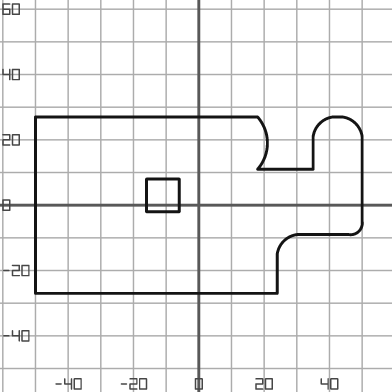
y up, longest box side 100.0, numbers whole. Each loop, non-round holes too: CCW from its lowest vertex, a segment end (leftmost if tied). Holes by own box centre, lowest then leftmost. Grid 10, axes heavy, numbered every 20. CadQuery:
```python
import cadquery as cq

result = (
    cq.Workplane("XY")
    .moveTo(-50.0, -27.0)
    .lineTo(24.0, -27.0)
    .lineTo(24.0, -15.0)
    .threePointArc((26.0, -11.0), (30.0, -9.0))
    .lineTo(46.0, -9.0)
    .threePointArc((49.0, -8.0), (50.0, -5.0))
    .lineTo(50.0, 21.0)
    .threePointArc((48.0, 25.0), (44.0, 27.0))
    .lineTo(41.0, 27.0)
    .threePointArc((37.0, 25.0), (35.0, 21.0))
    .lineTo(35.0, 11.0)
    .lineTo(18.0, 11.0)
    .threePointArc((21.0, 19.0), (18.0, 27.0))
    .lineTo(-50.0, 27.0)
    .close()
    .moveTo(-16.0, -2.0)
    .lineTo(-6.0, -2.0)
    .lineTo(-6.0, 8.0)
    .lineTo(-16.0, 8.0)
    .close()
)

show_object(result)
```